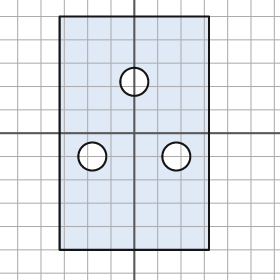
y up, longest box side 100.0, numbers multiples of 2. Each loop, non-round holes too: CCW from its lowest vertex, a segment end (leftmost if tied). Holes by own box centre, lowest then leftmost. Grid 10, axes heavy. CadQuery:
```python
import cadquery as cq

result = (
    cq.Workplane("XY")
    .moveTo(-32.0, -50.0)
    .lineTo(32.0, -50.0)
    .lineTo(32.0, 50.0)
    .lineTo(-32.0, 50.0)
    .close()
    .moveTo(-18.0, -10.0)
    .circle(6.0)
    .moveTo(18.0, -10.0)
    .circle(6.0)
    .moveTo(0.0, 22.0)
    .circle(6.0)
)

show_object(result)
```